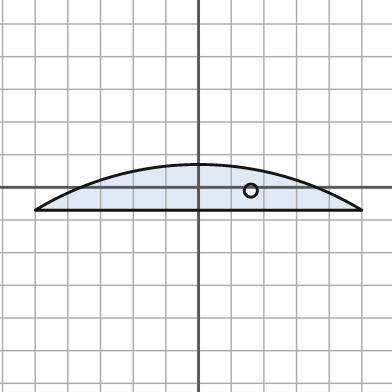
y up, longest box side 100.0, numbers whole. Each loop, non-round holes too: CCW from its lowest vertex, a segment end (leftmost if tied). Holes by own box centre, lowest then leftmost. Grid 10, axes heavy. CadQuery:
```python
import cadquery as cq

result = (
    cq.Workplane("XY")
    .moveTo(-50.0, -7.0)
    .lineTo(50.0, -7.0)
    .threePointArc((0.0, 7.0), (-50.0, -7.0))
    .close()
    .moveTo(16.0, -1.0)
    .circle(2.0)
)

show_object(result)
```